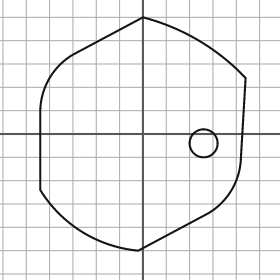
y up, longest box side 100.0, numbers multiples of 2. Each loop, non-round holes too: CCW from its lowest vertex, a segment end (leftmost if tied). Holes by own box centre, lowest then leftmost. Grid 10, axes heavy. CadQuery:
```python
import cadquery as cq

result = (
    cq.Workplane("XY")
    .moveTo(-2.0, -50.0)
    .lineTo(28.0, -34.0)
    .threePointArc((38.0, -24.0), (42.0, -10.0))
    .lineTo(44.0, 24.0)
    .threePointArc((24.0, 40.0), (0.0, 50.0))
    .lineTo(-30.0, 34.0)
    .threePointArc((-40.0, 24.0), (-44.0, 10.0))
    .lineTo(-44.0, -24.0)
    .threePointArc((-26.0, -42.0), (-2.0, -50.0))
    .close()
    .moveTo(26.0, -4.0)
    .circle(6.0)
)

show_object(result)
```